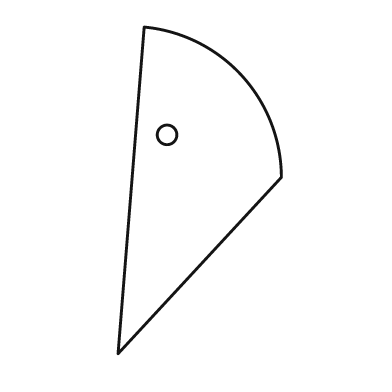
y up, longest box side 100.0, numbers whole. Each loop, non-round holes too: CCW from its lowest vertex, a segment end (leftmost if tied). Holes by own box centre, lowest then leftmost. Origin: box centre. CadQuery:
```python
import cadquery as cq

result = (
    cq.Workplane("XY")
    .moveTo(-25.0, -50.0)
    .lineTo(25.0, 4.0)
    .threePointArc((13.0, 35.0), (-17.0, 50.0))
    .close()
    .moveTo(-10.0, 17.0)
    .circle(3.0)
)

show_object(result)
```